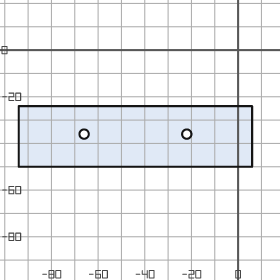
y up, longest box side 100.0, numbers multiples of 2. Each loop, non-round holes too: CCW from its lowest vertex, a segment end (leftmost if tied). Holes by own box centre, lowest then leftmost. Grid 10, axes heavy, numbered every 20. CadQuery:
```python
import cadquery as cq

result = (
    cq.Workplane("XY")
    .moveTo(-94.0, -50.0)
    .lineTo(6.0, -50.0)
    .lineTo(6.0, -24.0)
    .lineTo(-94.0, -24.0)
    .close()
    .moveTo(-66.0, -36.0)
    .circle(2.0)
    .moveTo(-22.0, -36.0)
    .circle(2.0)
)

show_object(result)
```